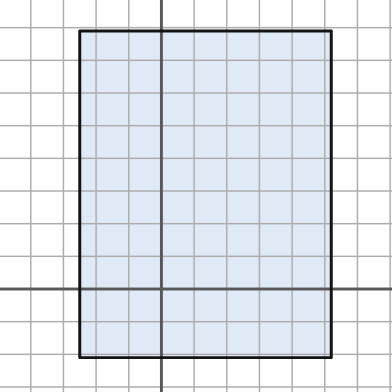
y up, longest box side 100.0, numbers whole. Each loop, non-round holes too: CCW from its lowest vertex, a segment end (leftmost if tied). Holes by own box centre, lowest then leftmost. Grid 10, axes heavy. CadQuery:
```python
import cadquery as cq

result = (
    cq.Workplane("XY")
    .moveTo(-25.0, -21.0)
    .lineTo(52.0, -21.0)
    .lineTo(52.0, 79.0)
    .lineTo(-25.0, 79.0)
    .close()
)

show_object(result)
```